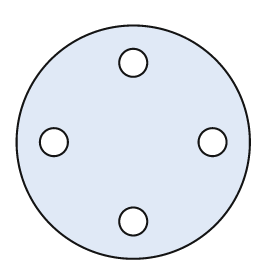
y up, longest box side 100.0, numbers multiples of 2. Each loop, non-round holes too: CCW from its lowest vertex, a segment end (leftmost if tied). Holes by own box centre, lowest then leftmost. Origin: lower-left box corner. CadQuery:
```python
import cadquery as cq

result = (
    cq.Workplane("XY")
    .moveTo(50.0, 50.0)
    .circle(50.0)
    .moveTo(50.0, 16.0)
    .circle(6.0)
    .moveTo(16.0, 50.0)
    .circle(6.0)
    .moveTo(84.0, 50.0)
    .circle(6.0)
    .moveTo(50.0, 84.0)
    .circle(6.0)
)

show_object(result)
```